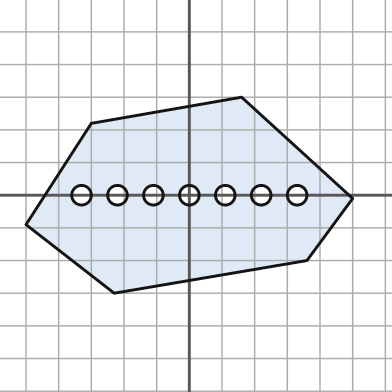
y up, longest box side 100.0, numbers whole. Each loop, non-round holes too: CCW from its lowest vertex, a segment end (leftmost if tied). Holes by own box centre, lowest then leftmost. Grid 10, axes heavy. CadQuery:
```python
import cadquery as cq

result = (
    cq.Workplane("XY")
    .moveTo(-23.0, -30.0)
    .lineTo(36.0, -20.0)
    .lineTo(50.0, -1.0)
    .lineTo(16.0, 30.0)
    .lineTo(-30.0, 22.0)
    .lineTo(-50.0, -9.0)
    .close()
    .moveTo(-33.0, 0.0)
    .circle(3.0)
    .moveTo(-22.0, 0.0)
    .circle(3.0)
    .moveTo(-11.0, 0.0)
    .circle(3.0)
    .moveTo(0.0, 0.0)
    .circle(3.0)
    .moveTo(11.0, 0.0)
    .circle(3.0)
    .moveTo(22.0, 0.0)
    .circle(3.0)
    .moveTo(33.0, 0.0)
    .circle(3.0)
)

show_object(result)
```